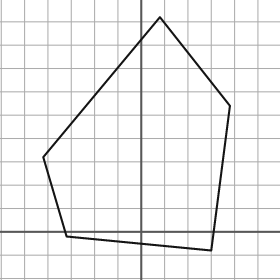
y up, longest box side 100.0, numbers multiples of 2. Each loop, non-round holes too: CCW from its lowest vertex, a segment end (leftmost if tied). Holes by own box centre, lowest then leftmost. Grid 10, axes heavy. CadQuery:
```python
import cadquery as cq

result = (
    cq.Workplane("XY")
    .moveTo(30.0, -8.0)
    .lineTo(38.0, 54.0)
    .lineTo(8.0, 92.0)
    .lineTo(-42.0, 32.0)
    .lineTo(-32.0, -2.0)
    .close()
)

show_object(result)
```